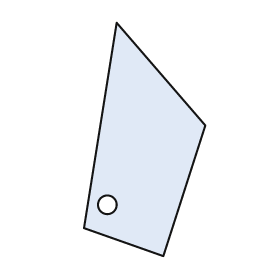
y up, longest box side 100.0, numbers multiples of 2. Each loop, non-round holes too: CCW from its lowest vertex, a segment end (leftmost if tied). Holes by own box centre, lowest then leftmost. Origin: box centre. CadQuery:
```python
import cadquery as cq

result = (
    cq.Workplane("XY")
    .moveTo(8.0, -50.0)
    .lineTo(26.0, 6.0)
    .lineTo(-12.0, 50.0)
    .lineTo(-26.0, -38.0)
    .close()
    .moveTo(-16.0, -28.0)
    .circle(4.0)
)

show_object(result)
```